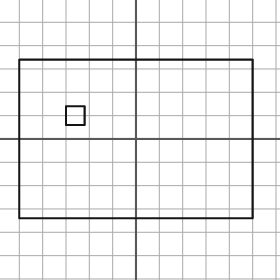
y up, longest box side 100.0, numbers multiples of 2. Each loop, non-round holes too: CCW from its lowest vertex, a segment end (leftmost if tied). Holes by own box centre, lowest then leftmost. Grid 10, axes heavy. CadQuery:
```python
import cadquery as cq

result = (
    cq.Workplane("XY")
    .moveTo(-50.0, -34.0)
    .lineTo(50.0, -34.0)
    .lineTo(50.0, 34.0)
    .lineTo(-50.0, 34.0)
    .close()
    .moveTo(-30.0, 6.0)
    .lineTo(-22.0, 6.0)
    .lineTo(-22.0, 14.0)
    .lineTo(-30.0, 14.0)
    .close()
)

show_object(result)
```